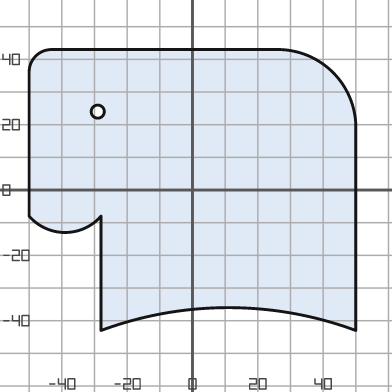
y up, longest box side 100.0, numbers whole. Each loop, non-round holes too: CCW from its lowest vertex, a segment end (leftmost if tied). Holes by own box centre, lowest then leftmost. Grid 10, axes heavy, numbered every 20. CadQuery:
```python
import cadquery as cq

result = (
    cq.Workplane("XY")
    .moveTo(-28.0, -43.0)
    .threePointArc((11.0, -36.0), (50.0, -43.0))
    .lineTo(50.0, 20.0)
    .threePointArc((43.0, 36.0), (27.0, 43.0))
    .lineTo(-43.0, 43.0)
    .threePointArc((-48.0, 41.0), (-50.0, 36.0))
    .lineTo(-50.0, -8.0)
    .threePointArc((-39.0, -13.0), (-28.0, -8.0))
    .close()
    .moveTo(-29.0, 24.0)
    .circle(2.0)
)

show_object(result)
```